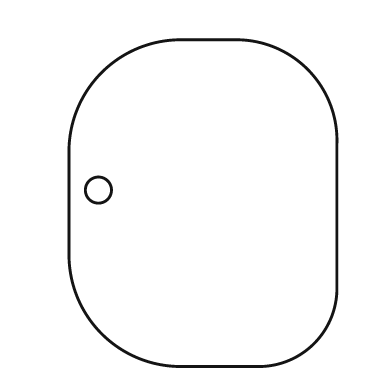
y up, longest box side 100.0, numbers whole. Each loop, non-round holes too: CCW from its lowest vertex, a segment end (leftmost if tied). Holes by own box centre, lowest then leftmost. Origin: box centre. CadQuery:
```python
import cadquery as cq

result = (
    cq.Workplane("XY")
    .moveTo(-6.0, -50.0)
    .lineTo(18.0, -50.0)
    .threePointArc((34.0, -43.0), (41.0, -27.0))
    .lineTo(41.0, 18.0)
    .threePointArc((32.0, 41.0), (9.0, 50.0))
    .lineTo(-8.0, 50.0)
    .threePointArc((-31.0, 40.0), (-41.0, 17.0))
    .lineTo(-41.0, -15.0)
    .threePointArc((-31.0, -40.0), (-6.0, -50.0))
    .close()
    .moveTo(-32.0, 4.0)
    .circle(4.0)
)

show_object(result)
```